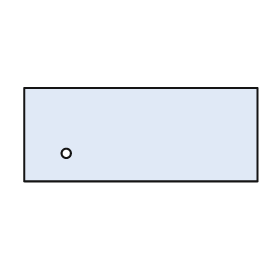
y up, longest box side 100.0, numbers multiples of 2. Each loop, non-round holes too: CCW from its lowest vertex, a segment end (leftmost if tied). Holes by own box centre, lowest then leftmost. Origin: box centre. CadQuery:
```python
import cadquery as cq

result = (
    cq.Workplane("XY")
    .moveTo(-50.0, -20.0)
    .lineTo(50.0, -20.0)
    .lineTo(50.0, 20.0)
    .lineTo(-50.0, 20.0)
    .close()
    .moveTo(-32.0, -8.0)
    .circle(2.0)
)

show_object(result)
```